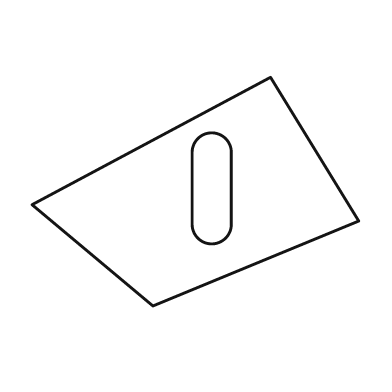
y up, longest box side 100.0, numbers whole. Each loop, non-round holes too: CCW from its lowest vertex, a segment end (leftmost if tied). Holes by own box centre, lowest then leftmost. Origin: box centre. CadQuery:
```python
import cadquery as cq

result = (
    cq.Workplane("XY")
    .moveTo(-13.0, -35.0)
    .lineTo(50.0, -9.0)
    .lineTo(23.0, 35.0)
    .lineTo(-50.0, -4.0)
    .close()
    .moveTo(-1.0, -10.0)
    .threePointArc((5.0, -16.0), (11.0, -10.0))
    .lineTo(11.0, 12.0)
    .threePointArc((5.0, 18.0), (-1.0, 12.0))
    .close()
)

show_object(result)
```